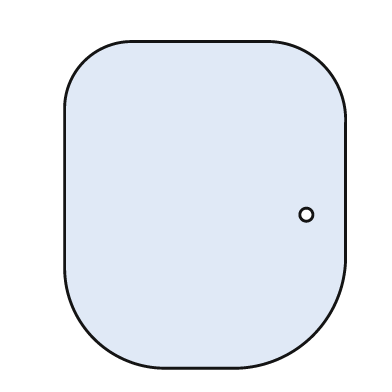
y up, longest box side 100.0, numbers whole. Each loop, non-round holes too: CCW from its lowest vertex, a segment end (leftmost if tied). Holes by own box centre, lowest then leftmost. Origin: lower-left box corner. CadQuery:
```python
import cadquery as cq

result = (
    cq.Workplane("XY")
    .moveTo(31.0, 0.0)
    .lineTo(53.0, 0.0)
    .threePointArc((76.0, 10.0), (86.0, 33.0))
    .lineTo(86.0, 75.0)
    .threePointArc((79.0, 93.0), (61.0, 100.0))
    .lineTo(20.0, 100.0)
    .threePointArc((6.0, 94.0), (0.0, 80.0))
    .lineTo(0.0, 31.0)
    .threePointArc((9.0, 9.0), (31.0, 0.0))
    .close()
    .moveTo(74.0, 47.0)
    .circle(2.0)
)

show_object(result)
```